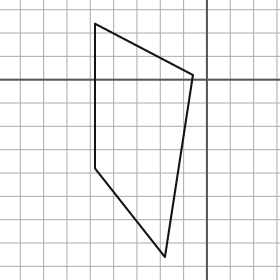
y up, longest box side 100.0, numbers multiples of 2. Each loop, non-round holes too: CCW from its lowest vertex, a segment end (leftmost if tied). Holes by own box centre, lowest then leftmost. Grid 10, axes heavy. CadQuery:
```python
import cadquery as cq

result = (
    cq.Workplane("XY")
    .moveTo(-18.0, -76.0)
    .lineTo(-6.0, 2.0)
    .lineTo(-48.0, 24.0)
    .lineTo(-48.0, -38.0)
    .close()
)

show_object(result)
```